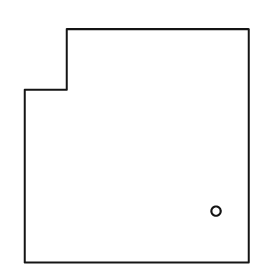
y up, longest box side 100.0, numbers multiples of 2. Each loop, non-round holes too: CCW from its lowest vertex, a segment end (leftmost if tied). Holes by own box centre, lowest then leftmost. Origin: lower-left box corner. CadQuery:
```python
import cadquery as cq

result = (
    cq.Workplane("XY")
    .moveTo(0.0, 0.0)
    .lineTo(96.0, 0.0)
    .lineTo(96.0, 100.0)
    .lineTo(18.0, 100.0)
    .lineTo(18.0, 74.0)
    .lineTo(0.0, 74.0)
    .close()
    .moveTo(82.0, 22.0)
    .circle(2.0)
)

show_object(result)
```